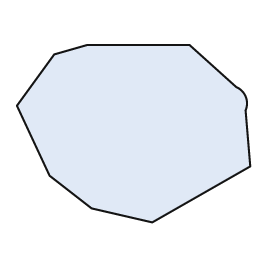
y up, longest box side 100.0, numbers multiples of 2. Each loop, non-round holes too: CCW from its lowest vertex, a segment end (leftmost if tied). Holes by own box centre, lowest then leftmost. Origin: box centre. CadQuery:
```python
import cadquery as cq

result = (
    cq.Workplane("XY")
    .moveTo(8.0, -38.0)
    .lineTo(50.0, -14.0)
    .lineTo(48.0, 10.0)
    .threePointArc((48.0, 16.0), (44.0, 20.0))
    .lineTo(24.0, 38.0)
    .lineTo(-20.0, 38.0)
    .lineTo(-34.0, 34.0)
    .lineTo(-50.0, 12.0)
    .lineTo(-36.0, -18.0)
    .lineTo(-18.0, -32.0)
    .close()
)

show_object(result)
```